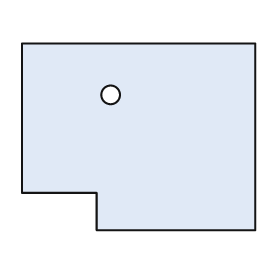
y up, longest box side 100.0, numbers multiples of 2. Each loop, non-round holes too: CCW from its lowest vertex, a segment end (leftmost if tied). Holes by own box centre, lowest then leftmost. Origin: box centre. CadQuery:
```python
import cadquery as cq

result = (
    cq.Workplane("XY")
    .moveTo(-18.0, -40.0)
    .lineTo(50.0, -40.0)
    .lineTo(50.0, 40.0)
    .lineTo(-50.0, 40.0)
    .lineTo(-50.0, -24.0)
    .lineTo(-18.0, -24.0)
    .close()
    .moveTo(-12.0, 18.0)
    .circle(4.0)
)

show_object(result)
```